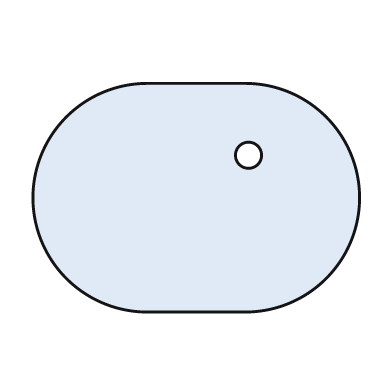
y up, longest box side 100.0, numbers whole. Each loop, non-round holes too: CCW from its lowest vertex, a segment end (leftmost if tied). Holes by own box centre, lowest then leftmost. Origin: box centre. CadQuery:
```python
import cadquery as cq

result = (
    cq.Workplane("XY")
    .moveTo(-15.0, -35.0)
    .lineTo(15.0, -35.0)
    .threePointArc((50.0, 0.0), (15.0, 35.0))
    .lineTo(-15.0, 35.0)
    .threePointArc((-50.0, 0.0), (-15.0, -35.0))
    .close()
    .moveTo(16.0, 13.0)
    .circle(4.0)
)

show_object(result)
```